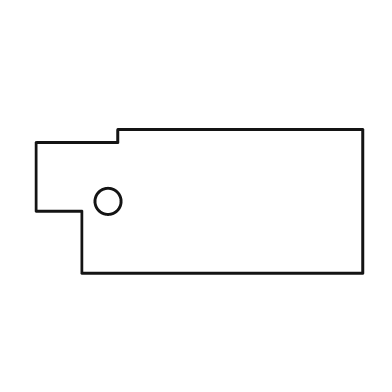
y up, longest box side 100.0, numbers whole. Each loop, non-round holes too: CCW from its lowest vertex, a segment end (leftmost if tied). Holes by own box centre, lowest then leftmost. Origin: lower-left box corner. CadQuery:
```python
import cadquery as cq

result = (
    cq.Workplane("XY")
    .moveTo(14.0, 0.0)
    .lineTo(100.0, 0.0)
    .lineTo(100.0, 44.0)
    .lineTo(25.0, 44.0)
    .lineTo(25.0, 40.0)
    .lineTo(0.0, 40.0)
    .lineTo(0.0, 19.0)
    .lineTo(14.0, 19.0)
    .close()
    .moveTo(22.0, 22.0)
    .circle(4.0)
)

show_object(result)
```